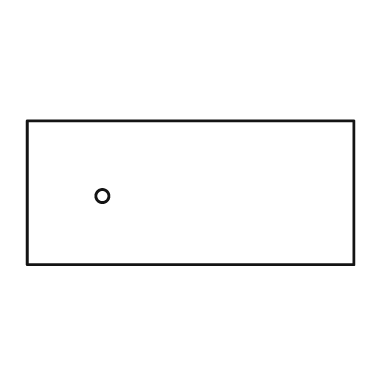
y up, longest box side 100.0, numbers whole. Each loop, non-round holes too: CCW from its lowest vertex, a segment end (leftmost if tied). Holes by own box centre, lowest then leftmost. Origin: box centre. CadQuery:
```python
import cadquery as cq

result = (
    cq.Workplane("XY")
    .moveTo(-50.0, -22.0)
    .lineTo(50.0, -22.0)
    .lineTo(50.0, 22.0)
    .lineTo(-50.0, 22.0)
    .close()
    .moveTo(-27.0, -1.0)
    .circle(2.0)
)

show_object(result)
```